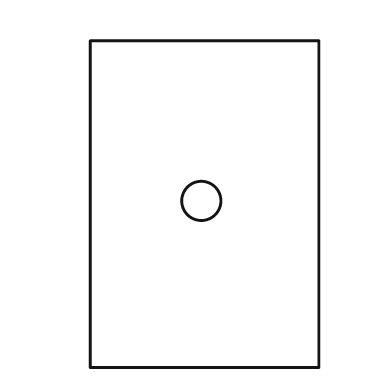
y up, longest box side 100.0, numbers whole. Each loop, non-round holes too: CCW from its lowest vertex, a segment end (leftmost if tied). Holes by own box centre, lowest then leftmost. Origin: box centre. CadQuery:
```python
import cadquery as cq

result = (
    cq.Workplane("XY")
    .moveTo(-35.0, -50.0)
    .lineTo(35.0, -50.0)
    .lineTo(35.0, 50.0)
    .lineTo(-35.0, 50.0)
    .close()
    .moveTo(-1.0, 1.0)
    .circle(6.0)
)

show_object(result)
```